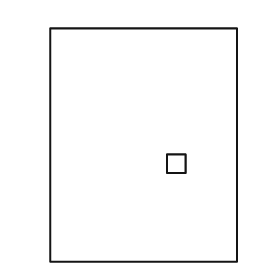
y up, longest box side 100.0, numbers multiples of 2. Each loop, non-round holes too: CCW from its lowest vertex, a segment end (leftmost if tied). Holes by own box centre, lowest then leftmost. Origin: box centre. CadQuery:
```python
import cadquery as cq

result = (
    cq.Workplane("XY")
    .moveTo(-40.0, -50.0)
    .lineTo(40.0, -50.0)
    .lineTo(40.0, 50.0)
    .lineTo(-40.0, 50.0)
    .close()
    .moveTo(10.0, -12.0)
    .lineTo(18.0, -12.0)
    .lineTo(18.0, -4.0)
    .lineTo(10.0, -4.0)
    .close()
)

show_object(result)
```